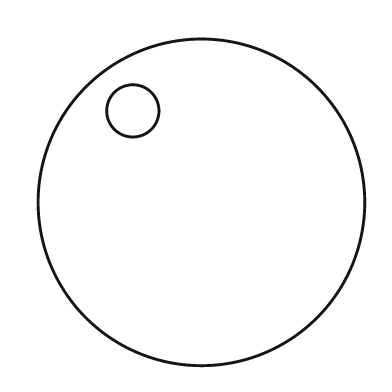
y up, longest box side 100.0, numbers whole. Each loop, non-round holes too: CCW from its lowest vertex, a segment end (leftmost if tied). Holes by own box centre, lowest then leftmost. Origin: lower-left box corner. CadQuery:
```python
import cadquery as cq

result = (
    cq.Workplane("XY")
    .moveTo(50.0, 50.0)
    .circle(50.0)
    .moveTo(29.0, 78.0)
    .circle(8.0)
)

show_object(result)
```